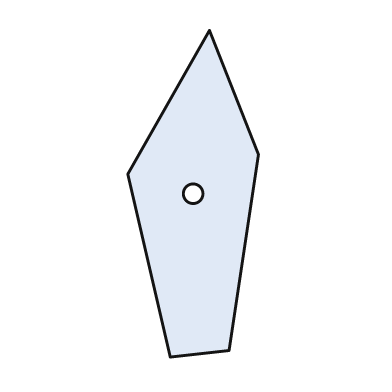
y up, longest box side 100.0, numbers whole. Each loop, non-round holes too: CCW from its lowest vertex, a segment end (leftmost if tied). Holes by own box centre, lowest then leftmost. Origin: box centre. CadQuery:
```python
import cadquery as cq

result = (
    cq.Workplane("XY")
    .moveTo(-7.0, -50.0)
    .lineTo(11.0, -48.0)
    .lineTo(20.0, 12.0)
    .lineTo(5.0, 50.0)
    .lineTo(-20.0, 6.0)
    .close()
    .moveTo(0.0, 0.0)
    .circle(3.0)
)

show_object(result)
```